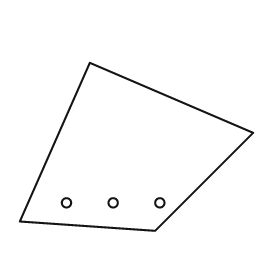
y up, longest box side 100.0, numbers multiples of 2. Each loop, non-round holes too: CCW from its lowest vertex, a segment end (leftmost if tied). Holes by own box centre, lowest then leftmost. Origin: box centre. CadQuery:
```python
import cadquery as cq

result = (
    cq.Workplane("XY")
    .moveTo(8.0, -36.0)
    .lineTo(50.0, 6.0)
    .lineTo(-20.0, 36.0)
    .lineTo(-50.0, -32.0)
    .close()
    .moveTo(-30.0, -24.0)
    .circle(2.0)
    .moveTo(-10.0, -24.0)
    .circle(2.0)
    .moveTo(10.0, -24.0)
    .circle(2.0)
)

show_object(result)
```